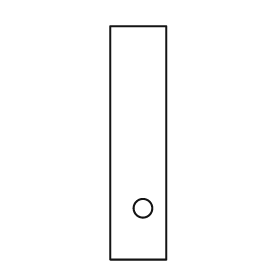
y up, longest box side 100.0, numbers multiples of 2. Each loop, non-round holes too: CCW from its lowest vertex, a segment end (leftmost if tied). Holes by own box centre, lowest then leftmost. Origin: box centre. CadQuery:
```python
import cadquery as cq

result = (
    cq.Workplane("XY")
    .moveTo(-12.0, -50.0)
    .lineTo(12.0, -50.0)
    .lineTo(12.0, 50.0)
    .lineTo(-12.0, 50.0)
    .close()
    .moveTo(2.0, -28.0)
    .circle(4.0)
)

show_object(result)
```